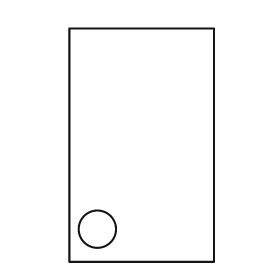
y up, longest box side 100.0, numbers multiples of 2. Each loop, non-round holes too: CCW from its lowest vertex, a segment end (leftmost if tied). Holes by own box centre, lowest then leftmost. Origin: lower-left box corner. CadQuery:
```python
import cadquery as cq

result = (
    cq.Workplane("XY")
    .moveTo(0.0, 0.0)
    .lineTo(62.0, 0.0)
    .lineTo(62.0, 100.0)
    .lineTo(0.0, 100.0)
    .close()
    .moveTo(12.0, 14.0)
    .circle(8.0)
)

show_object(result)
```